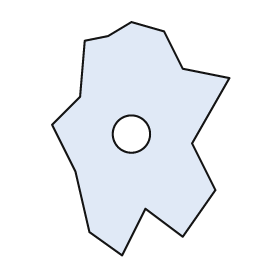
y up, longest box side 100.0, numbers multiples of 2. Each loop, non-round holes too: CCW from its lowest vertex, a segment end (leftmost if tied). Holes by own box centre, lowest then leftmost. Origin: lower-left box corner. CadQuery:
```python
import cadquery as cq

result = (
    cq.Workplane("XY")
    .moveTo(30.0, 0.0)
    .lineTo(40.0, 20.0)
    .lineTo(56.0, 8.0)
    .lineTo(70.0, 28.0)
    .lineTo(60.0, 48.0)
    .lineTo(76.0, 76.0)
    .lineTo(56.0, 80.0)
    .lineTo(48.0, 96.0)
    .lineTo(34.0, 100.0)
    .lineTo(24.0, 94.0)
    .lineTo(14.0, 92.0)
    .lineTo(12.0, 68.0)
    .lineTo(0.0, 56.0)
    .lineTo(10.0, 36.0)
    .lineTo(16.0, 10.0)
    .close()
    .moveTo(34.0, 52.0)
    .circle(8.0)
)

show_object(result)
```